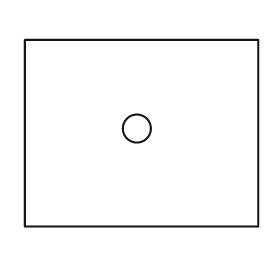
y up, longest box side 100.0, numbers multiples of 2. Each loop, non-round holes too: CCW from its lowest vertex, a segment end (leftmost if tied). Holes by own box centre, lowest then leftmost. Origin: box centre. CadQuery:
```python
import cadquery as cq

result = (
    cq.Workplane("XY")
    .moveTo(-50.0, -40.0)
    .lineTo(50.0, -40.0)
    .lineTo(50.0, 40.0)
    .lineTo(-50.0, 40.0)
    .close()
    .moveTo(-2.0, 2.0)
    .circle(6.0)
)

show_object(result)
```